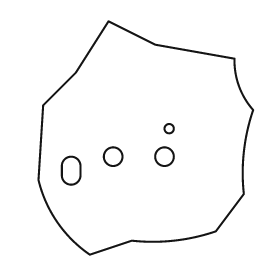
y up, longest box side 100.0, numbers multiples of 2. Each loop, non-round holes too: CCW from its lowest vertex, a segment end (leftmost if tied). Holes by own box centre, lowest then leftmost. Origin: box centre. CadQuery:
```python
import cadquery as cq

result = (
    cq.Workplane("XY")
    .moveTo(-24.0, -50.0)
    .lineTo(-6.0, -44.0)
    .threePointArc((12.0, -44.0), (30.0, -40.0))
    .lineTo(42.0, -24.0)
    .threePointArc((42.0, -6.0), (46.0, 12.0))
    .threePointArc((40.0, 22.0), (38.0, 34.0))
    .lineTo(4.0, 40.0)
    .lineTo(-16.0, 50.0)
    .lineTo(-30.0, 28.0)
    .lineTo(-44.0, 14.0)
    .lineTo(-46.0, -18.0)
    .threePointArc((-38.0, -36.0), (-24.0, -50.0))
    .close()
    .moveTo(-36.0, -16.0)
    .threePointArc((-32.0, -20.0), (-28.0, -16.0))
    .lineTo(-28.0, -12.0)
    .threePointArc((-32.0, -8.0), (-36.0, -12.0))
    .close()
    .moveTo(-14.0, -8.0)
    .circle(4.0)
    .moveTo(8.0, -8.0)
    .circle(4.0)
    .moveTo(10.0, 4.0)
    .circle(2.0)
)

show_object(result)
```